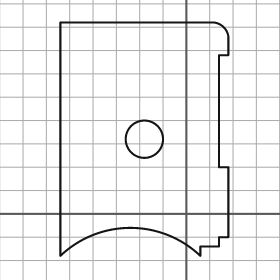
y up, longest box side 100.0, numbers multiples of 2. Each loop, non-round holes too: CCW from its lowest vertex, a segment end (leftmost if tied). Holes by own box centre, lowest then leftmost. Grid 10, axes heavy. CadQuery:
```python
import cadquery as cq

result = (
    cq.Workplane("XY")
    .moveTo(-54.0, -18.0)
    .threePointArc((-24.0, -6.0), (6.0, -18.0))
    .lineTo(6.0, -14.0)
    .lineTo(14.0, -14.0)
    .lineTo(14.0, -10.0)
    .lineTo(18.0, -10.0)
    .lineTo(18.0, 20.0)
    .lineTo(14.0, 20.0)
    .lineTo(14.0, 68.0)
    .lineTo(18.0, 68.0)
    .lineTo(18.0, 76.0)
    .threePointArc((16.0, 80.0), (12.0, 82.0))
    .lineTo(-54.0, 82.0)
    .close()
    .moveTo(-18.0, 32.0)
    .circle(8.0)
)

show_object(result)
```